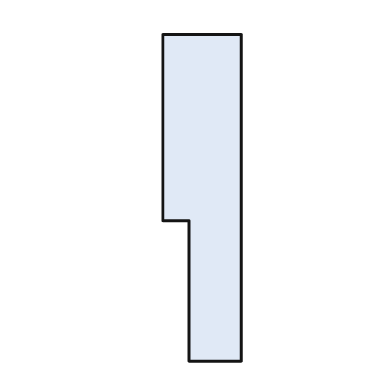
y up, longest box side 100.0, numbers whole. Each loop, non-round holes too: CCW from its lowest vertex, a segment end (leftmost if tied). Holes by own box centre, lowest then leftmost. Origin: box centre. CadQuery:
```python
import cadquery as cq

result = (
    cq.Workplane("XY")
    .moveTo(-4.0, -50.0)
    .lineTo(12.0, -50.0)
    .lineTo(12.0, 50.0)
    .lineTo(-12.0, 50.0)
    .lineTo(-12.0, -7.0)
    .lineTo(-4.0, -7.0)
    .close()
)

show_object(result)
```